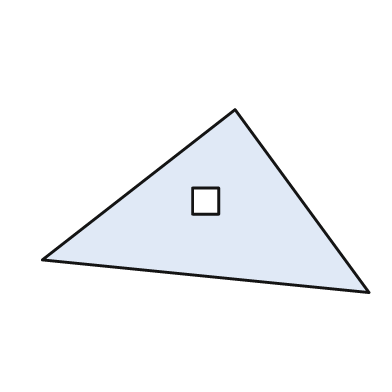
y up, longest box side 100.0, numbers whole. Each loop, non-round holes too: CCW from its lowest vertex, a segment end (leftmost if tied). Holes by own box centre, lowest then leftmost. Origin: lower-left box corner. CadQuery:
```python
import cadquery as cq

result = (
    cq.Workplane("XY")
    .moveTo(100.0, 0.0)
    .lineTo(59.0, 56.0)
    .lineTo(0.0, 10.0)
    .close()
    .moveTo(46.0, 24.0)
    .lineTo(54.0, 24.0)
    .lineTo(54.0, 32.0)
    .lineTo(46.0, 32.0)
    .close()
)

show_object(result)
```